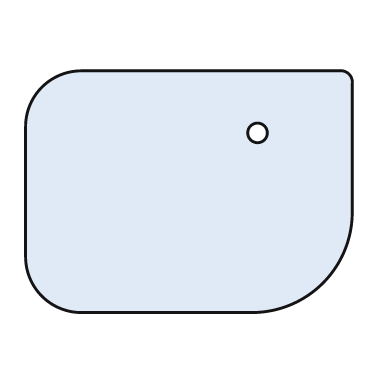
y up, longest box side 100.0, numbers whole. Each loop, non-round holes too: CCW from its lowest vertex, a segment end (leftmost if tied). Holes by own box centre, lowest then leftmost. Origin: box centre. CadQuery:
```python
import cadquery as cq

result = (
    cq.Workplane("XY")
    .moveTo(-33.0, -37.0)
    .lineTo(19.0, -37.0)
    .threePointArc((41.0, -28.0), (50.0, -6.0))
    .lineTo(50.0, 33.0)
    .threePointArc((49.0, 36.0), (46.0, 37.0))
    .lineTo(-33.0, 37.0)
    .threePointArc((-45.0, 32.0), (-50.0, 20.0))
    .lineTo(-50.0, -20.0)
    .threePointArc((-45.0, -32.0), (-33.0, -37.0))
    .close()
    .moveTo(21.0, 18.0)
    .circle(3.0)
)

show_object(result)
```